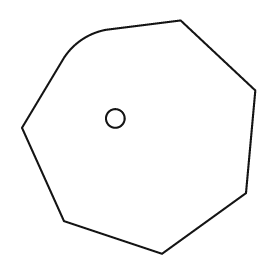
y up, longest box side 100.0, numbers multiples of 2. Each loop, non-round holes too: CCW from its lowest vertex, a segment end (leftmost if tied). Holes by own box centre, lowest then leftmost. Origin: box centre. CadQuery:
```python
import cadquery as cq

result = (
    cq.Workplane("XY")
    .moveTo(10.0, -50.0)
    .lineTo(46.0, -24.0)
    .lineTo(50.0, 20.0)
    .lineTo(18.0, 50.0)
    .lineTo(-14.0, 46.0)
    .threePointArc((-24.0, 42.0), (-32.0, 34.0))
    .lineTo(-50.0, 4.0)
    .lineTo(-32.0, -36.0)
    .close()
    .moveTo(-10.0, 8.0)
    .circle(4.0)
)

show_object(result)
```